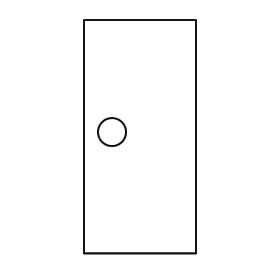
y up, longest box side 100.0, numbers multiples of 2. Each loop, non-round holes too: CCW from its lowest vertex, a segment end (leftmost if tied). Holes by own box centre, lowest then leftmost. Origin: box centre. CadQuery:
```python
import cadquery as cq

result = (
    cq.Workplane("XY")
    .moveTo(-24.0, -50.0)
    .lineTo(24.0, -50.0)
    .lineTo(24.0, 50.0)
    .lineTo(-24.0, 50.0)
    .close()
    .moveTo(-12.0, 2.0)
    .circle(6.0)
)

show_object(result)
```